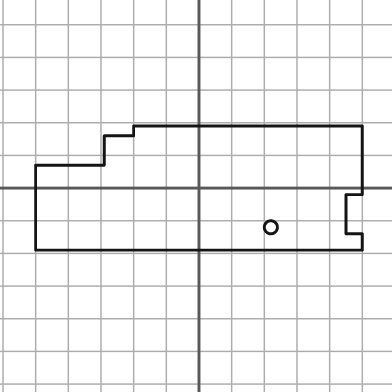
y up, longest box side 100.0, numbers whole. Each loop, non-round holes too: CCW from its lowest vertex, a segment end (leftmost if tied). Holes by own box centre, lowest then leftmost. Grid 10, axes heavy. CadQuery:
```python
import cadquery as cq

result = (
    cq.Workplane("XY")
    .moveTo(-50.0, -19.0)
    .lineTo(50.0, -19.0)
    .lineTo(50.0, -14.0)
    .lineTo(45.0, -14.0)
    .lineTo(45.0, -2.0)
    .lineTo(50.0, -2.0)
    .lineTo(50.0, 19.0)
    .lineTo(-20.0, 19.0)
    .lineTo(-20.0, 16.0)
    .lineTo(-29.0, 16.0)
    .lineTo(-29.0, 7.0)
    .lineTo(-50.0, 7.0)
    .close()
    .moveTo(22.0, -12.0)
    .circle(2.0)
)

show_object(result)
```